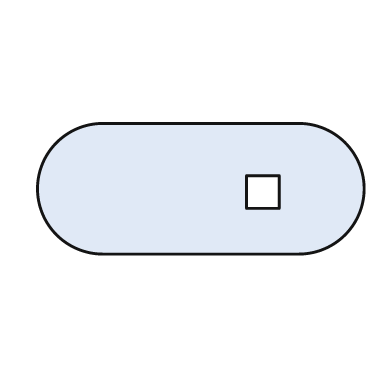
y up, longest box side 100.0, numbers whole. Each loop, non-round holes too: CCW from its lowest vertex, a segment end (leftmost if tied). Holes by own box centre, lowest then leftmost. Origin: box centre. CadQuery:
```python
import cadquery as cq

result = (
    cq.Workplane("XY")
    .moveTo(-30.0, -20.0)
    .lineTo(30.0, -20.0)
    .threePointArc((50.0, 0.0), (30.0, 20.0))
    .lineTo(-30.0, 20.0)
    .threePointArc((-50.0, 0.0), (-30.0, -20.0))
    .close()
    .moveTo(14.0, -6.0)
    .lineTo(24.0, -6.0)
    .lineTo(24.0, 4.0)
    .lineTo(14.0, 4.0)
    .close()
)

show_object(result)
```